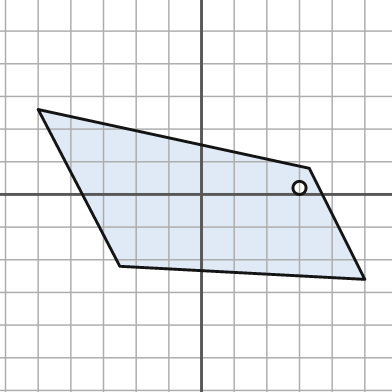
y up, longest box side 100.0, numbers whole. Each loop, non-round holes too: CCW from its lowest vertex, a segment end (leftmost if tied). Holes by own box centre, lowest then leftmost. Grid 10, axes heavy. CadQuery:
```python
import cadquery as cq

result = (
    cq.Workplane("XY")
    .moveTo(50.0, -26.0)
    .lineTo(33.0, 8.0)
    .lineTo(-50.0, 26.0)
    .lineTo(-25.0, -22.0)
    .close()
    .moveTo(30.0, 2.0)
    .circle(2.0)
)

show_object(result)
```